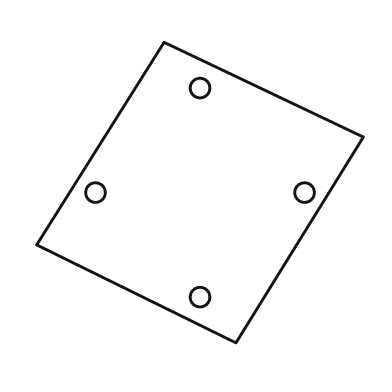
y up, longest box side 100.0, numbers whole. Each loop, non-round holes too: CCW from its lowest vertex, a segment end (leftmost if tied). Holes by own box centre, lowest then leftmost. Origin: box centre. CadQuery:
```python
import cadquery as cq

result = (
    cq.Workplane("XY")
    .moveTo(11.0, -46.0)
    .lineTo(50.0, 17.0)
    .lineTo(-11.0, 46.0)
    .lineTo(-50.0, -16.0)
    .close()
    .moveTo(0.0, -32.0)
    .circle(3.0)
    .moveTo(-32.0, 0.0)
    .circle(3.0)
    .moveTo(32.0, 0.0)
    .circle(3.0)
    .moveTo(0.0, 32.0)
    .circle(3.0)
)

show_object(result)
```